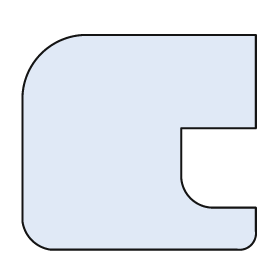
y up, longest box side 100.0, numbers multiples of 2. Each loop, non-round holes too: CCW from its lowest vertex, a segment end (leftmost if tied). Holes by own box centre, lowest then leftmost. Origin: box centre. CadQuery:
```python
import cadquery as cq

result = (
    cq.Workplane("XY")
    .moveTo(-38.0, -46.0)
    .lineTo(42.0, -46.0)
    .threePointArc((48.0, -44.0), (50.0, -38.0))
    .lineTo(50.0, -28.0)
    .lineTo(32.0, -28.0)
    .threePointArc((22.0, -24.0), (18.0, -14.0))
    .lineTo(18.0, 6.0)
    .lineTo(50.0, 6.0)
    .lineTo(50.0, 46.0)
    .lineTo(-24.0, 46.0)
    .threePointArc((-42.0, 38.0), (-50.0, 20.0))
    .lineTo(-50.0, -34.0)
    .threePointArc((-46.0, -42.0), (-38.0, -46.0))
    .close()
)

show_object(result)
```